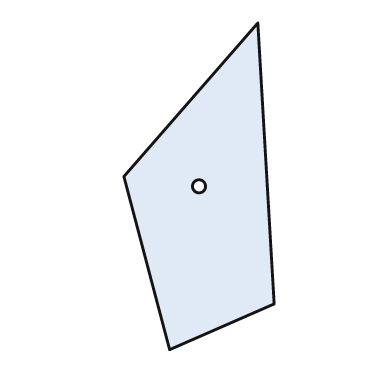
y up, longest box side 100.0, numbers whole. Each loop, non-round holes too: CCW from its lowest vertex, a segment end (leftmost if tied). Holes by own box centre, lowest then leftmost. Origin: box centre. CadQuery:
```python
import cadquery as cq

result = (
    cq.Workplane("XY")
    .moveTo(-9.0, -50.0)
    .lineTo(23.0, -36.0)
    .lineTo(18.0, 50.0)
    .lineTo(-23.0, 3.0)
    .close()
    .moveTo(0.0, 0.0)
    .circle(2.0)
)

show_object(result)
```